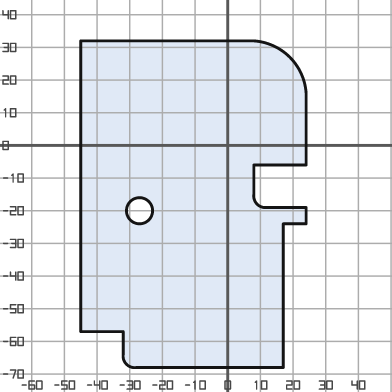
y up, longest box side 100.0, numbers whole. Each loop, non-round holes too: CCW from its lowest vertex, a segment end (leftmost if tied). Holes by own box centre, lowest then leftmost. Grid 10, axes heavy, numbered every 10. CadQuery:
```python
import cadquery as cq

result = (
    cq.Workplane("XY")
    .moveTo(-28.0, -68.0)
    .lineTo(17.0, -68.0)
    .lineTo(17.0, -24.0)
    .lineTo(24.0, -24.0)
    .lineTo(24.0, -19.0)
    .lineTo(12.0, -19.0)
    .threePointArc((9.0, -18.0), (8.0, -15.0))
    .lineTo(8.0, -6.0)
    .lineTo(24.0, -6.0)
    .lineTo(24.0, 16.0)
    .threePointArc((19.0, 27.0), (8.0, 32.0))
    .lineTo(-45.0, 32.0)
    .lineTo(-45.0, -57.0)
    .lineTo(-32.0, -57.0)
    .lineTo(-32.0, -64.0)
    .threePointArc((-31.0, -67.0), (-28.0, -68.0))
    .close()
    .moveTo(-27.0, -20.0)
    .circle(4.0)
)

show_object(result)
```